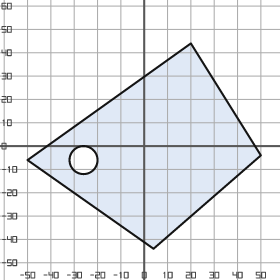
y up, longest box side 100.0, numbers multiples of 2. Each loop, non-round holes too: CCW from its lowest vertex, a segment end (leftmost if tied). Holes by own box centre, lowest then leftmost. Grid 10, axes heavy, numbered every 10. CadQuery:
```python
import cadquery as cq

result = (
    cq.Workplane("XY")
    .moveTo(4.0, -44.0)
    .lineTo(50.0, -4.0)
    .lineTo(20.0, 44.0)
    .lineTo(-50.0, -6.0)
    .close()
    .moveTo(-26.0, -6.0)
    .circle(6.0)
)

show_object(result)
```